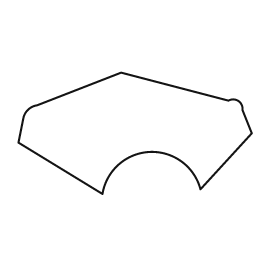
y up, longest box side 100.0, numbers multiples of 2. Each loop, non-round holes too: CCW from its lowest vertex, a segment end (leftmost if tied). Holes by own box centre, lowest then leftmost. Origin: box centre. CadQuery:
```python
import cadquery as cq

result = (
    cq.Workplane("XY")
    .moveTo(-14.0, -26.0)
    .threePointArc((6.0, -8.0), (28.0, -24.0))
    .lineTo(50.0, 0.0)
    .lineTo(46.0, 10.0)
    .threePointArc((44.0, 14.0), (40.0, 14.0))
    .lineTo(-6.0, 26.0)
    .lineTo(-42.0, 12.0)
    .threePointArc((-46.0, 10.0), (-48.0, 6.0))
    .lineTo(-50.0, -4.0)
    .close()
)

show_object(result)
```